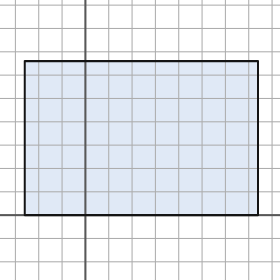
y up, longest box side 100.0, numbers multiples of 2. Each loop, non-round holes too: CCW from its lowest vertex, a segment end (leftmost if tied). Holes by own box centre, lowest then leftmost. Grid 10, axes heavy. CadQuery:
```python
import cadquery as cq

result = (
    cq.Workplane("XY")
    .moveTo(-26.0, 0.0)
    .lineTo(74.0, 0.0)
    .lineTo(74.0, 66.0)
    .lineTo(-26.0, 66.0)
    .close()
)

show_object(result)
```